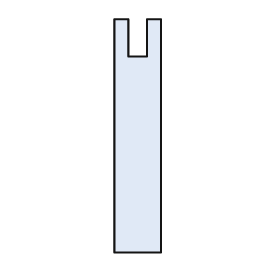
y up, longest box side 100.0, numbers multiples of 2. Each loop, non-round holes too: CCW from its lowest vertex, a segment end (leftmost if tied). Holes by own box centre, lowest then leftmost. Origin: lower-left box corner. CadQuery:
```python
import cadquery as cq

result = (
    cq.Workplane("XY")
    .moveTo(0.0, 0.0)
    .lineTo(20.0, 0.0)
    .lineTo(20.0, 100.0)
    .lineTo(14.0, 100.0)
    .lineTo(14.0, 84.0)
    .lineTo(6.0, 84.0)
    .lineTo(6.0, 100.0)
    .lineTo(0.0, 100.0)
    .close()
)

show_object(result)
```